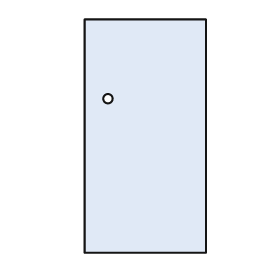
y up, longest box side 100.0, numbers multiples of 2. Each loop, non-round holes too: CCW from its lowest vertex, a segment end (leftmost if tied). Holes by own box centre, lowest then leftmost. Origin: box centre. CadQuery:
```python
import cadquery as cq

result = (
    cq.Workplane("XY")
    .moveTo(-26.0, -50.0)
    .lineTo(26.0, -50.0)
    .lineTo(26.0, 50.0)
    .lineTo(-26.0, 50.0)
    .close()
    .moveTo(-16.0, 16.0)
    .circle(2.0)
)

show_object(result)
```